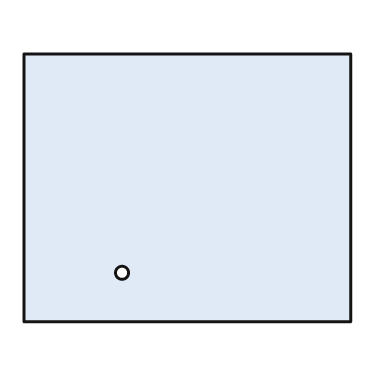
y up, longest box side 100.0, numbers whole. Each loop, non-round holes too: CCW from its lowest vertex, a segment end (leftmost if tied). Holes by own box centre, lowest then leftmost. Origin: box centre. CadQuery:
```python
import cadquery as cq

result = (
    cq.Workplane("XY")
    .moveTo(-50.0, -41.0)
    .lineTo(50.0, -41.0)
    .lineTo(50.0, 41.0)
    .lineTo(-50.0, 41.0)
    .close()
    .moveTo(-20.0, -26.0)
    .circle(2.0)
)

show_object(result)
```